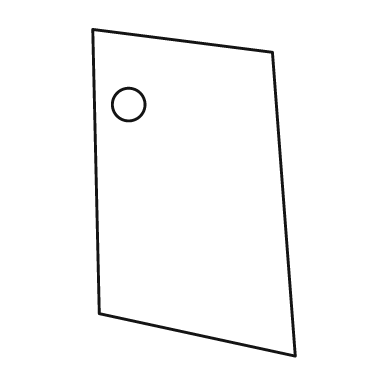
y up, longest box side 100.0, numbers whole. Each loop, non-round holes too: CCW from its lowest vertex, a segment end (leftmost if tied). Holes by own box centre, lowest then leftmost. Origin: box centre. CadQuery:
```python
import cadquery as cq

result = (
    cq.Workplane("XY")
    .moveTo(31.0, -50.0)
    .lineTo(24.0, 43.0)
    .lineTo(-31.0, 50.0)
    .lineTo(-29.0, -37.0)
    .close()
    .moveTo(-20.0, 27.0)
    .circle(5.0)
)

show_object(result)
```